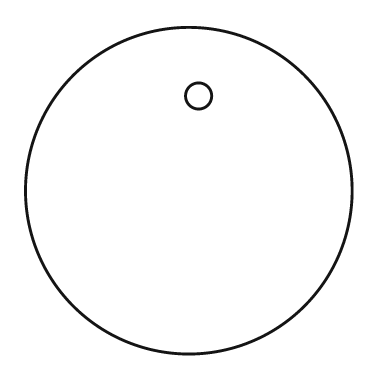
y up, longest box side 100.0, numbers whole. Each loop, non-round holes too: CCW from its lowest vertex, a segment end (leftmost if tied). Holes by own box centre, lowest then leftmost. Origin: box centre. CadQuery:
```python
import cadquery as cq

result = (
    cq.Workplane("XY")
    .moveTo(0.0, 0.0)
    .circle(50.0)
    .moveTo(3.0, 29.0)
    .circle(4.0)
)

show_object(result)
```